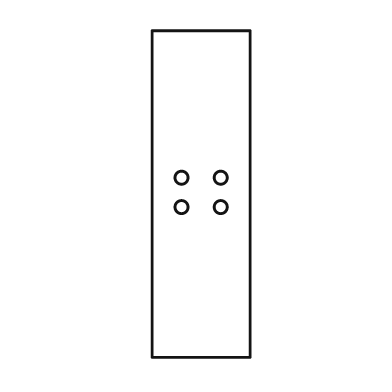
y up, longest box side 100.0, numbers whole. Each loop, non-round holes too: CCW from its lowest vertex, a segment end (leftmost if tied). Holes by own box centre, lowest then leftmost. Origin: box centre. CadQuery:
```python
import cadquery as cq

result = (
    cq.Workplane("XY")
    .moveTo(-15.0, -50.0)
    .lineTo(15.0, -50.0)
    .lineTo(15.0, 50.0)
    .lineTo(-15.0, 50.0)
    .close()
    .moveTo(-6.0, -4.0)
    .circle(2.0)
    .moveTo(6.0, -4.0)
    .circle(2.0)
    .moveTo(-6.0, 5.0)
    .circle(2.0)
    .moveTo(6.0, 5.0)
    .circle(2.0)
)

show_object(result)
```